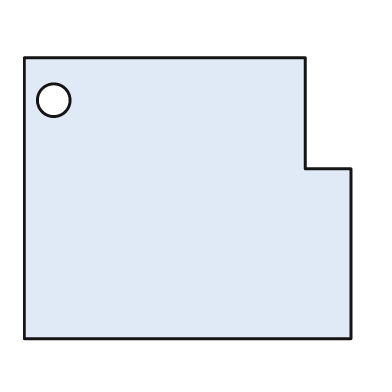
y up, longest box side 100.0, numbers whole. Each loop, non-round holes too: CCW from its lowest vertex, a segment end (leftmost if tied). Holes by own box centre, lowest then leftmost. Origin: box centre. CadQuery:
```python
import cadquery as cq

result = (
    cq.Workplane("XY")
    .moveTo(-50.0, -43.0)
    .lineTo(50.0, -43.0)
    .lineTo(50.0, 9.0)
    .lineTo(36.0, 9.0)
    .lineTo(36.0, 43.0)
    .lineTo(-50.0, 43.0)
    .close()
    .moveTo(-41.0, 30.0)
    .circle(5.0)
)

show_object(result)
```